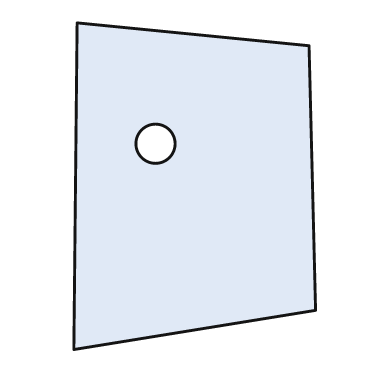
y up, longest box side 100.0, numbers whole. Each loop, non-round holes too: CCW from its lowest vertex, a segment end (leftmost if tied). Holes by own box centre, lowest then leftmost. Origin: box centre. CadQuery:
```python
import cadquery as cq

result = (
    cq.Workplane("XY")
    .moveTo(-37.0, -50.0)
    .lineTo(37.0, -38.0)
    .lineTo(35.0, 43.0)
    .lineTo(-36.0, 50.0)
    .close()
    .moveTo(-12.0, 13.0)
    .circle(6.0)
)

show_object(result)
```